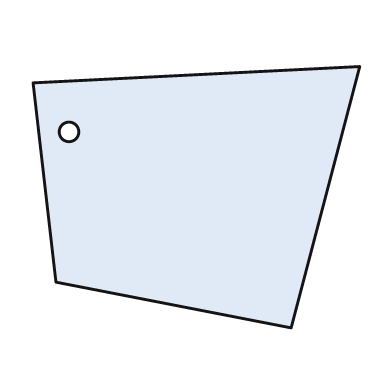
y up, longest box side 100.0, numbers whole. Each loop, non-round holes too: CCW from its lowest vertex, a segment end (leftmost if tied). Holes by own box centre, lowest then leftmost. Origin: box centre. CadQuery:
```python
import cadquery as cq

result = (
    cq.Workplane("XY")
    .moveTo(29.0, -40.0)
    .lineTo(50.0, 40.0)
    .lineTo(-50.0, 35.0)
    .lineTo(-43.0, -26.0)
    .close()
    .moveTo(-39.0, 20.0)
    .circle(3.0)
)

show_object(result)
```